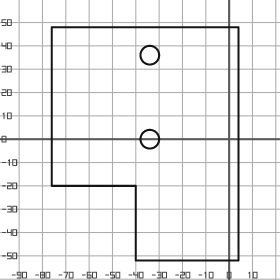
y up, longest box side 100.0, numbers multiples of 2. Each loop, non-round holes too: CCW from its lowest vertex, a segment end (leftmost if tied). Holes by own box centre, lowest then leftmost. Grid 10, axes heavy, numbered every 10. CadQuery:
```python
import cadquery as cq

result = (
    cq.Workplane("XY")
    .moveTo(-40.0, -52.0)
    .lineTo(4.0, -52.0)
    .lineTo(4.0, 48.0)
    .lineTo(-76.0, 48.0)
    .lineTo(-76.0, -20.0)
    .lineTo(-40.0, -20.0)
    .close()
    .moveTo(-34.0, 0.0)
    .circle(4.0)
    .moveTo(-34.0, 36.0)
    .circle(4.0)
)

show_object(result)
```